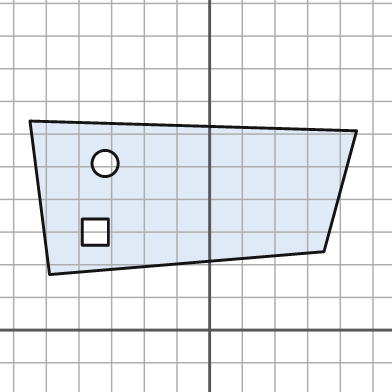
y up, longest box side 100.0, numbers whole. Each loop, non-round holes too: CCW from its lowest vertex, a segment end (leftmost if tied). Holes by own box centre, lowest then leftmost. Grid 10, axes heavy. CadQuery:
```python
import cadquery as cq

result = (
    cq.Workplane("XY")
    .moveTo(-49.0, 17.0)
    .lineTo(35.0, 24.0)
    .lineTo(45.0, 61.0)
    .lineTo(-55.0, 64.0)
    .close()
    .moveTo(-39.0, 26.0)
    .lineTo(-31.0, 26.0)
    .lineTo(-31.0, 34.0)
    .lineTo(-39.0, 34.0)
    .close()
    .moveTo(-32.0, 51.0)
    .circle(4.0)
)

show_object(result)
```